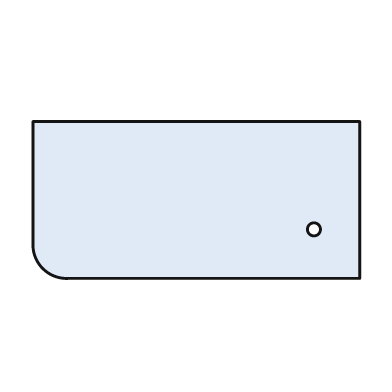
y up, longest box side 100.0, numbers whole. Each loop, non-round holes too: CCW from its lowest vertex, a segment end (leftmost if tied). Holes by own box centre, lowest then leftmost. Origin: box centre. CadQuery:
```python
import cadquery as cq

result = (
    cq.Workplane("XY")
    .moveTo(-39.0, -24.0)
    .lineTo(50.0, -24.0)
    .lineTo(50.0, 24.0)
    .lineTo(-50.0, 24.0)
    .lineTo(-50.0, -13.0)
    .threePointArc((-47.0, -21.0), (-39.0, -24.0))
    .close()
    .moveTo(36.0, -9.0)
    .circle(2.0)
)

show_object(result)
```